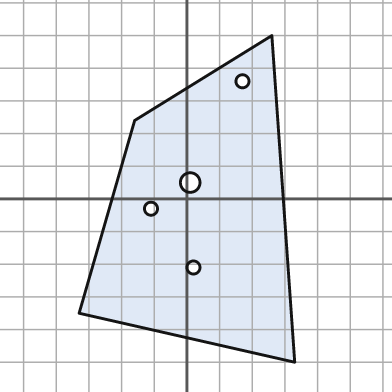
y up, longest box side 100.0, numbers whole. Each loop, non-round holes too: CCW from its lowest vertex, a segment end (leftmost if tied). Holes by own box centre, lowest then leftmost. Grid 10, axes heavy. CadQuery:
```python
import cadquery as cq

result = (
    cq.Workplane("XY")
    .moveTo(33.0, -50.0)
    .lineTo(26.0, 50.0)
    .lineTo(-16.0, 24.0)
    .lineTo(-33.0, -35.0)
    .close()
    .moveTo(2.0, -21.0)
    .circle(2.0)
    .moveTo(-11.0, -3.0)
    .circle(2.0)
    .moveTo(1.0, 5.0)
    .circle(3.0)
    .moveTo(17.0, 36.0)
    .circle(2.0)
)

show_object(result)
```